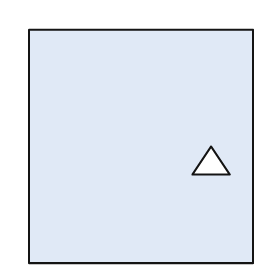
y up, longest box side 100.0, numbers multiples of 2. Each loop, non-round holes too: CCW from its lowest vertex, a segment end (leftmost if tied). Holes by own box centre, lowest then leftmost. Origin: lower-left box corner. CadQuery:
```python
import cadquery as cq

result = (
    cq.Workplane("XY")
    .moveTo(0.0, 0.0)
    .lineTo(96.0, 0.0)
    .lineTo(96.0, 100.0)
    .lineTo(0.0, 100.0)
    .close()
    .moveTo(70.0, 38.0)
    .lineTo(86.0, 38.0)
    .lineTo(78.0, 50.0)
    .close()
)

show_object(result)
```